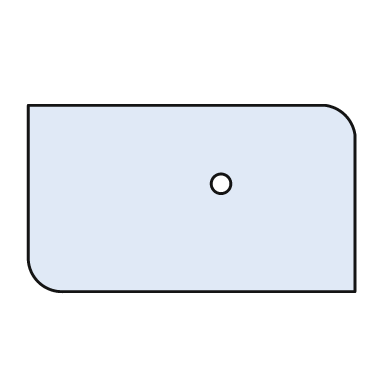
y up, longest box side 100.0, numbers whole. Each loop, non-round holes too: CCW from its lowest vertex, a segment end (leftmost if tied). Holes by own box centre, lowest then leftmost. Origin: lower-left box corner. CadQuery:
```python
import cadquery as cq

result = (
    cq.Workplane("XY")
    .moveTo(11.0, 0.0)
    .lineTo(100.0, 0.0)
    .lineTo(100.0, 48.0)
    .threePointArc((97.0, 54.0), (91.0, 57.0))
    .lineTo(0.0, 57.0)
    .lineTo(0.0, 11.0)
    .threePointArc((3.0, 3.0), (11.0, 0.0))
    .close()
    .moveTo(59.0, 33.0)
    .circle(3.0)
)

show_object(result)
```